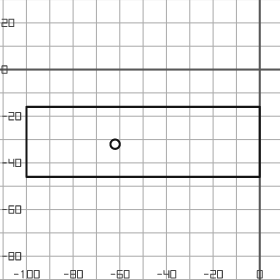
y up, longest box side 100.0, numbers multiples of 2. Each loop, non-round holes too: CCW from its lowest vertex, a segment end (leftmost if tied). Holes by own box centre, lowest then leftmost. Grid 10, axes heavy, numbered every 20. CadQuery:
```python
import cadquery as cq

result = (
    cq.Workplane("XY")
    .moveTo(-100.0, -46.0)
    .lineTo(0.0, -46.0)
    .lineTo(0.0, -16.0)
    .lineTo(-100.0, -16.0)
    .close()
    .moveTo(-62.0, -32.0)
    .circle(2.0)
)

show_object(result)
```